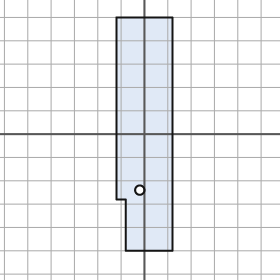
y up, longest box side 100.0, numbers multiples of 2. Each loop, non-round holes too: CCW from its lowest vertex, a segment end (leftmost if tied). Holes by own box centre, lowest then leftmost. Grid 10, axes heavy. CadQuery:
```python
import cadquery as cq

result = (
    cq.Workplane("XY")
    .moveTo(-8.0, -50.0)
    .lineTo(12.0, -50.0)
    .lineTo(12.0, 50.0)
    .lineTo(-12.0, 50.0)
    .lineTo(-12.0, -28.0)
    .lineTo(-8.0, -28.0)
    .close()
    .moveTo(-2.0, -24.0)
    .circle(2.0)
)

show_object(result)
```